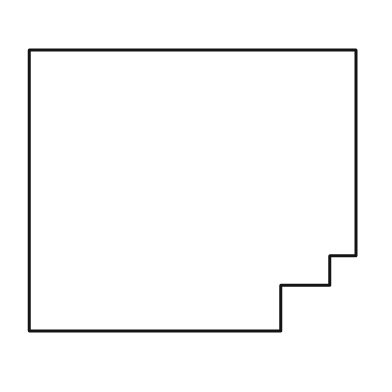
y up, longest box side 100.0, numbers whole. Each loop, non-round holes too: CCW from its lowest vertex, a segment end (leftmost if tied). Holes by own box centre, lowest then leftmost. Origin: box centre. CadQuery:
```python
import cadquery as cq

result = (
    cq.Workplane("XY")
    .moveTo(-50.0, -43.0)
    .lineTo(27.0, -43.0)
    .lineTo(27.0, -29.0)
    .lineTo(42.0, -29.0)
    .lineTo(42.0, -20.0)
    .lineTo(50.0, -20.0)
    .lineTo(50.0, 43.0)
    .lineTo(-50.0, 43.0)
    .close()
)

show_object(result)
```